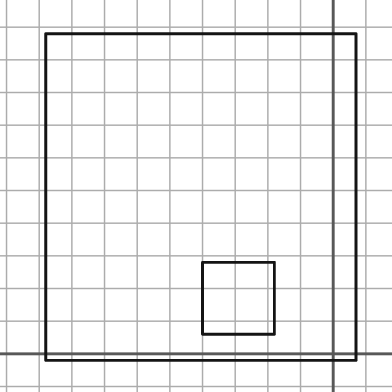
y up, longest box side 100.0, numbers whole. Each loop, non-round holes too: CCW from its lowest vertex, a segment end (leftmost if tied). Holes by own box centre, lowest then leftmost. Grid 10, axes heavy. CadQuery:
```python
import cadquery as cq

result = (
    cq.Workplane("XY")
    .moveTo(-88.0, -2.0)
    .lineTo(7.0, -2.0)
    .lineTo(7.0, 98.0)
    .lineTo(-88.0, 98.0)
    .close()
    .moveTo(-40.0, 6.0)
    .lineTo(-18.0, 6.0)
    .lineTo(-18.0, 28.0)
    .lineTo(-40.0, 28.0)
    .close()
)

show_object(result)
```